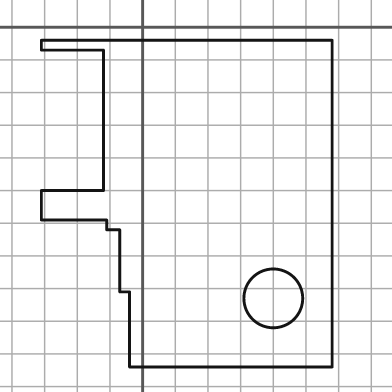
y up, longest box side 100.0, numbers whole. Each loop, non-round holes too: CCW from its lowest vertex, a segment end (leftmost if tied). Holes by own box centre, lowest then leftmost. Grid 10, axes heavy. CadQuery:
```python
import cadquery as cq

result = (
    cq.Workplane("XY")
    .moveTo(-4.0, -104.0)
    .lineTo(58.0, -104.0)
    .lineTo(58.0, -4.0)
    .lineTo(-31.0, -4.0)
    .lineTo(-31.0, -7.0)
    .lineTo(-12.0, -7.0)
    .lineTo(-12.0, -50.0)
    .lineTo(-31.0, -50.0)
    .lineTo(-31.0, -59.0)
    .lineTo(-11.0, -59.0)
    .lineTo(-11.0, -62.0)
    .lineTo(-7.0, -62.0)
    .lineTo(-7.0, -81.0)
    .lineTo(-4.0, -81.0)
    .close()
    .moveTo(40.0, -83.0)
    .circle(9.0)
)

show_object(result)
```